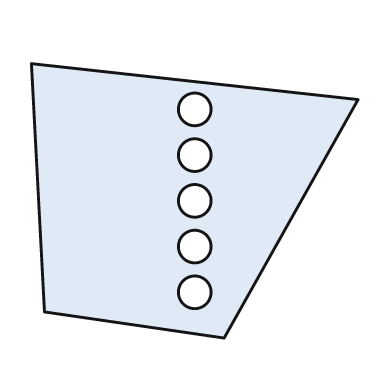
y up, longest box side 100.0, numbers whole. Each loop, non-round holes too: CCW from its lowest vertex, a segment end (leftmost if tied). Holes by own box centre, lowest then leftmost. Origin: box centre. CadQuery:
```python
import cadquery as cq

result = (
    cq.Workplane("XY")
    .moveTo(9.0, -42.0)
    .lineTo(50.0, 31.0)
    .lineTo(-50.0, 42.0)
    .lineTo(-46.0, -34.0)
    .close()
    .moveTo(0.0, -28.0)
    .circle(5.0)
    .moveTo(0.0, -14.0)
    .circle(5.0)
    .moveTo(0.0, 0.0)
    .circle(5.0)
    .moveTo(0.0, 14.0)
    .circle(5.0)
    .moveTo(0.0, 28.0)
    .circle(5.0)
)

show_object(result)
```